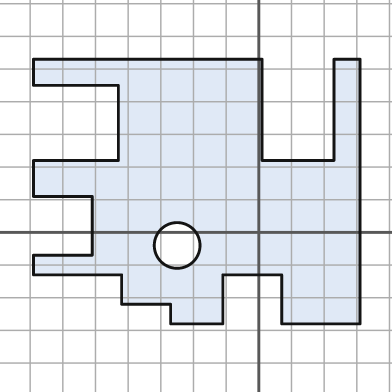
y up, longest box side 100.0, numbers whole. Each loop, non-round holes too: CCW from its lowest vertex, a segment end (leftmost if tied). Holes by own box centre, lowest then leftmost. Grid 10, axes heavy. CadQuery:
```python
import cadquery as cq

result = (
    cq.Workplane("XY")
    .moveTo(-27.0, -28.0)
    .lineTo(-11.0, -28.0)
    .lineTo(-11.0, -13.0)
    .lineTo(7.0, -13.0)
    .lineTo(7.0, -28.0)
    .lineTo(31.0, -28.0)
    .lineTo(31.0, 53.0)
    .lineTo(23.0, 53.0)
    .lineTo(23.0, 22.0)
    .lineTo(1.0, 22.0)
    .lineTo(1.0, 53.0)
    .lineTo(-69.0, 53.0)
    .lineTo(-69.0, 45.0)
    .lineTo(-43.0, 45.0)
    .lineTo(-43.0, 22.0)
    .lineTo(-69.0, 22.0)
    .lineTo(-69.0, 11.0)
    .lineTo(-51.0, 11.0)
    .lineTo(-51.0, -7.0)
    .lineTo(-69.0, -7.0)
    .lineTo(-69.0, -13.0)
    .lineTo(-42.0, -13.0)
    .lineTo(-42.0, -22.0)
    .lineTo(-27.0, -22.0)
    .close()
    .moveTo(-25.0, -4.0)
    .circle(7.0)
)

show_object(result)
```